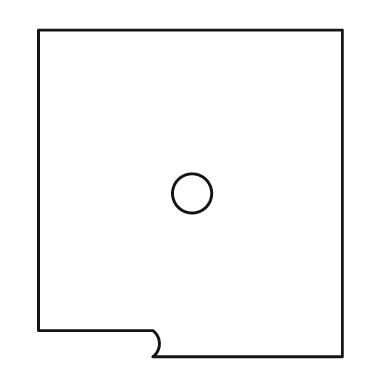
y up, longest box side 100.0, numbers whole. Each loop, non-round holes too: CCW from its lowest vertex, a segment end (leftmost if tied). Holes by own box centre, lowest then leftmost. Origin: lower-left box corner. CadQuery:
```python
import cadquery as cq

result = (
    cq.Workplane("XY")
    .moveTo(35.0, 0.0)
    .lineTo(93.0, 0.0)
    .lineTo(93.0, 100.0)
    .lineTo(0.0, 100.0)
    .lineTo(0.0, 8.0)
    .lineTo(35.0, 8.0)
    .threePointArc((37.0, 4.0), (35.0, 0.0))
    .close()
    .moveTo(47.0, 50.0)
    .circle(6.0)
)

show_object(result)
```